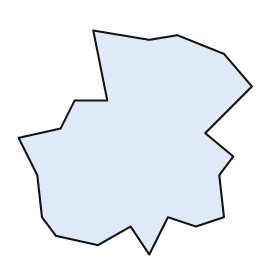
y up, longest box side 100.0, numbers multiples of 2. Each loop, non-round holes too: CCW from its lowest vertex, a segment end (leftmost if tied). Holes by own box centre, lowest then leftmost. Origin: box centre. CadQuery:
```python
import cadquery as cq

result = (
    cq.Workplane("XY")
    .moveTo(6.0, -48.0)
    .lineTo(14.0, -32.0)
    .lineTo(26.0, -36.0)
    .lineTo(38.0, -32.0)
    .lineTo(36.0, -14.0)
    .lineTo(42.0, -6.0)
    .lineTo(30.0, 4.0)
    .lineTo(50.0, 24.0)
    .lineTo(38.0, 38.0)
    .lineTo(18.0, 46.0)
    .lineTo(6.0, 44.0)
    .lineTo(-18.0, 48.0)
    .lineTo(-12.0, 18.0)
    .lineTo(-26.0, 18.0)
    .lineTo(-32.0, 6.0)
    .lineTo(-50.0, 2.0)
    .lineTo(-42.0, -14.0)
    .lineTo(-40.0, -32.0)
    .lineTo(-34.0, -40.0)
    .lineTo(-16.0, -44.0)
    .lineTo(-2.0, -36.0)
    .close()
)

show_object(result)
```